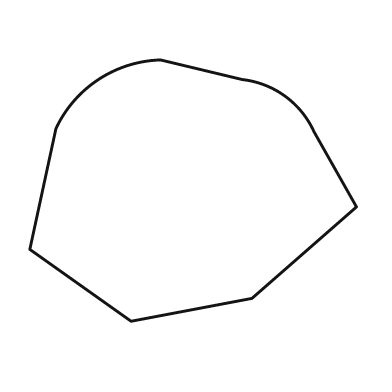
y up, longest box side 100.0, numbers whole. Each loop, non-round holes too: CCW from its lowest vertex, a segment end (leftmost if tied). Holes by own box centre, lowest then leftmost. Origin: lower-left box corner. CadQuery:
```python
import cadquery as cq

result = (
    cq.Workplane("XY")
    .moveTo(31.0, 0.0)
    .lineTo(68.0, 7.0)
    .lineTo(100.0, 35.0)
    .lineTo(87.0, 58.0)
    .threePointArc((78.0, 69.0), (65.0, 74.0))
    .lineTo(40.0, 80.0)
    .threePointArc((21.0, 74.0), (8.0, 59.0))
    .lineTo(0.0, 22.0)
    .close()
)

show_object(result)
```